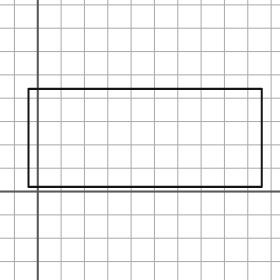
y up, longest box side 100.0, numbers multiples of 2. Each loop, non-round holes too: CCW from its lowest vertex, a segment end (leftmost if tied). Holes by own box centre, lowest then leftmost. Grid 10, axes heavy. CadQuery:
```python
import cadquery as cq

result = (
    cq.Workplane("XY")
    .moveTo(-4.0, 2.0)
    .lineTo(96.0, 2.0)
    .lineTo(96.0, 44.0)
    .lineTo(-4.0, 44.0)
    .close()
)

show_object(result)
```